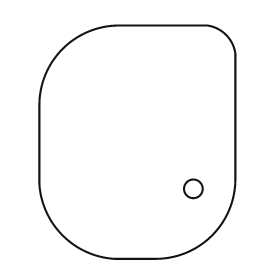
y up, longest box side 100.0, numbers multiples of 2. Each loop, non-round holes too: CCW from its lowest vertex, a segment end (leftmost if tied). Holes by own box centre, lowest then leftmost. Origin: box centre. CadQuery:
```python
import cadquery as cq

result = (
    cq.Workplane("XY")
    .moveTo(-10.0, -50.0)
    .lineTo(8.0, -50.0)
    .threePointArc((32.0, -40.0), (42.0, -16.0))
    .lineTo(42.0, 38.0)
    .threePointArc((38.0, 46.0), (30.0, 50.0))
    .lineTo(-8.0, 50.0)
    .threePointArc((-32.0, 40.0), (-42.0, 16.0))
    .lineTo(-42.0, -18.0)
    .threePointArc((-32.0, -40.0), (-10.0, -50.0))
    .close()
    .moveTo(24.0, -20.0)
    .circle(4.0)
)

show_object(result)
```